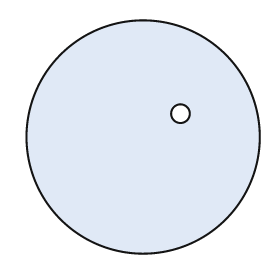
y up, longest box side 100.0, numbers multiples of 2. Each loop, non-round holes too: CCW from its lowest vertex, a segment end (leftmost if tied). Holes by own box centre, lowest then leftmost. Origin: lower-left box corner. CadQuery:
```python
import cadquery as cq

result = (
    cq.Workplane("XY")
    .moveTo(50.0, 50.0)
    .circle(50.0)
    .moveTo(66.0, 60.0)
    .circle(4.0)
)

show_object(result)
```